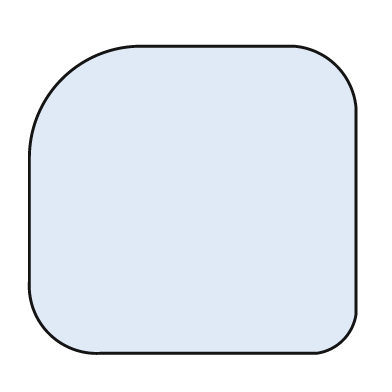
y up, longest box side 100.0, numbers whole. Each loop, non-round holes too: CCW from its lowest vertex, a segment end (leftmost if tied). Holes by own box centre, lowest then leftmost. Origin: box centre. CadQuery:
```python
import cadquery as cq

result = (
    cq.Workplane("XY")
    .moveTo(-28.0, -47.0)
    .lineTo(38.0, -47.0)
    .threePointArc((46.0, -43.0), (50.0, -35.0))
    .lineTo(50.0, 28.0)
    .threePointArc((44.0, 41.0), (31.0, 47.0))
    .lineTo(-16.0, 47.0)
    .threePointArc((-40.0, 37.0), (-50.0, 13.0))
    .lineTo(-50.0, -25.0)
    .threePointArc((-44.0, -41.0), (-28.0, -47.0))
    .close()
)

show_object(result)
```